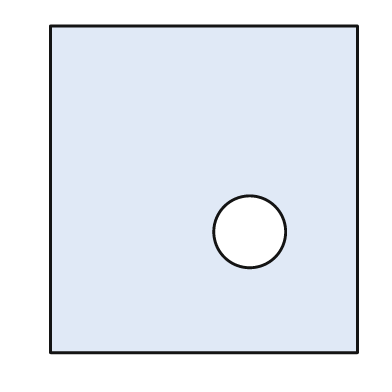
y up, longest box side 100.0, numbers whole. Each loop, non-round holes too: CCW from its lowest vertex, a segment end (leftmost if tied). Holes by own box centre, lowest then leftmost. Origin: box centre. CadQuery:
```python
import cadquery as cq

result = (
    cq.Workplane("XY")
    .moveTo(-47.0, -50.0)
    .lineTo(47.0, -50.0)
    .lineTo(47.0, 50.0)
    .lineTo(-47.0, 50.0)
    .close()
    .moveTo(14.0, -13.0)
    .circle(11.0)
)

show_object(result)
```